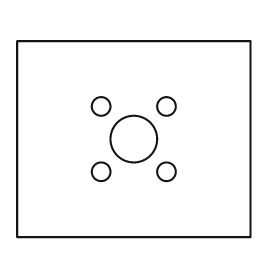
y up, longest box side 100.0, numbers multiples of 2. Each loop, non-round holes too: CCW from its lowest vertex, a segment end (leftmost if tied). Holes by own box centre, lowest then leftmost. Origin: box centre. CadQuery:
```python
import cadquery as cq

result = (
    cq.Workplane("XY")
    .moveTo(-50.0, -42.0)
    .lineTo(50.0, -42.0)
    .lineTo(50.0, 42.0)
    .lineTo(-50.0, 42.0)
    .close()
    .moveTo(-14.0, -14.0)
    .circle(4.0)
    .moveTo(14.0, -14.0)
    .circle(4.0)
    .moveTo(0.0, 0.0)
    .circle(10.0)
    .moveTo(-14.0, 14.0)
    .circle(4.0)
    .moveTo(14.0, 14.0)
    .circle(4.0)
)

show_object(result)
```